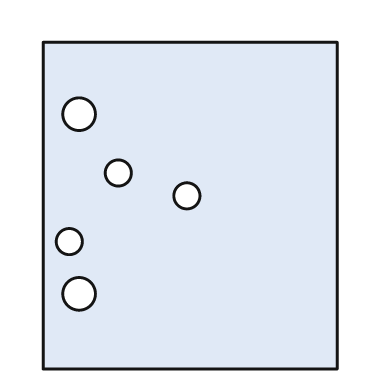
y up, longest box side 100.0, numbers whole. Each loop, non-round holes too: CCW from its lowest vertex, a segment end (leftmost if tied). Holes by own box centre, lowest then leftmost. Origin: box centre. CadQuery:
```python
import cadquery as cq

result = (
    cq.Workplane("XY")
    .moveTo(-45.0, -50.0)
    .lineTo(45.0, -50.0)
    .lineTo(45.0, 50.0)
    .lineTo(-45.0, 50.0)
    .close()
    .moveTo(-34.0, -27.0)
    .circle(5.0)
    .moveTo(-37.0, -11.0)
    .circle(4.0)
    .moveTo(-1.0, 3.0)
    .circle(4.0)
    .moveTo(-22.0, 10.0)
    .circle(4.0)
    .moveTo(-34.0, 28.0)
    .circle(5.0)
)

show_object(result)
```